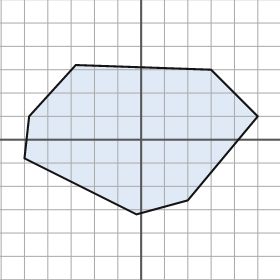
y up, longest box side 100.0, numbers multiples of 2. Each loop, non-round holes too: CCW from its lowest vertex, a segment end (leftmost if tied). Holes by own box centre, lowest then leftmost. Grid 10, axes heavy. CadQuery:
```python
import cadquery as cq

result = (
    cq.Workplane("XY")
    .moveTo(-2.0, -32.0)
    .lineTo(20.0, -26.0)
    .lineTo(50.0, 10.0)
    .lineTo(30.0, 30.0)
    .lineTo(-28.0, 32.0)
    .lineTo(-48.0, 10.0)
    .lineTo(-50.0, -8.0)
    .close()
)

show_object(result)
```